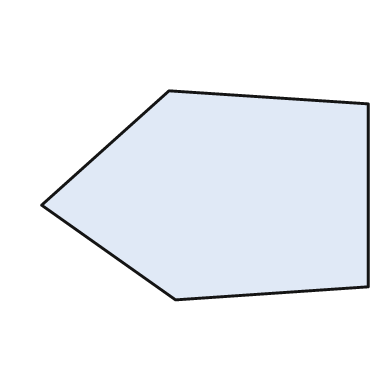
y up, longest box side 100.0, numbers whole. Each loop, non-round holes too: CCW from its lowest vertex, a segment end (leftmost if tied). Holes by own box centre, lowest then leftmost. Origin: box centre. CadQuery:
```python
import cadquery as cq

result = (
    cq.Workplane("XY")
    .moveTo(-9.0, -32.0)
    .lineTo(50.0, -28.0)
    .lineTo(50.0, 28.0)
    .lineTo(-11.0, 32.0)
    .lineTo(-50.0, -3.0)
    .close()
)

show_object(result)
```